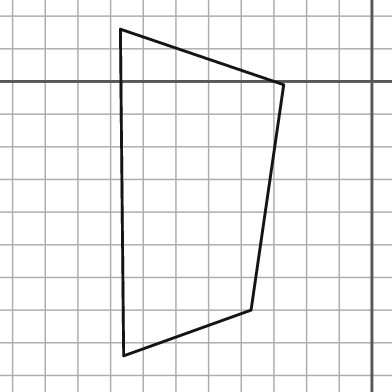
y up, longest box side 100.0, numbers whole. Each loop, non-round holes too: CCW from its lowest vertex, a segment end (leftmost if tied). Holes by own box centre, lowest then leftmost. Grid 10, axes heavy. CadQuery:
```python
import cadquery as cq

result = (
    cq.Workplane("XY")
    .moveTo(-76.0, -84.0)
    .lineTo(-37.0, -70.0)
    .lineTo(-27.0, -1.0)
    .lineTo(-77.0, 16.0)
    .close()
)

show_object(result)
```